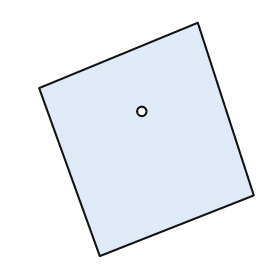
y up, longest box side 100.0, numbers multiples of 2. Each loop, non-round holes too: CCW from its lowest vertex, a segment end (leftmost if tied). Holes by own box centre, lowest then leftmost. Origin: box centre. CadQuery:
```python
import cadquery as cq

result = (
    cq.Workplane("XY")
    .moveTo(-20.0, -50.0)
    .lineTo(46.0, -24.0)
    .lineTo(22.0, 50.0)
    .lineTo(-46.0, 22.0)
    .close()
    .moveTo(-2.0, 12.0)
    .circle(2.0)
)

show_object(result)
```